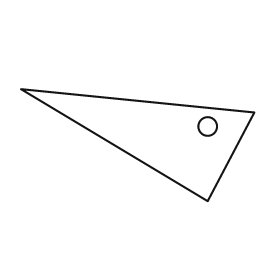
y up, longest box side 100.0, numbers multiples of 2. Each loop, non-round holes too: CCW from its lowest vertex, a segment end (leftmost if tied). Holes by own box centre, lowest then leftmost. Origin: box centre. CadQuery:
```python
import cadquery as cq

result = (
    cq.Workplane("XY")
    .moveTo(30.0, -24.0)
    .lineTo(50.0, 14.0)
    .lineTo(-50.0, 24.0)
    .close()
    .moveTo(30.0, 8.0)
    .circle(4.0)
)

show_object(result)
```